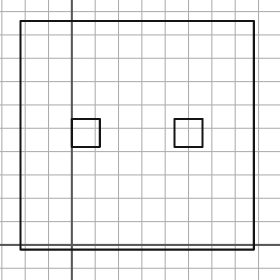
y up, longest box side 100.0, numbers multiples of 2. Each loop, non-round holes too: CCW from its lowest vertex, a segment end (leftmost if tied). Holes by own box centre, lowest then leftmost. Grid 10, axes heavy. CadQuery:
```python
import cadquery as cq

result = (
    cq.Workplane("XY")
    .moveTo(-22.0, -2.0)
    .lineTo(78.0, -2.0)
    .lineTo(78.0, 96.0)
    .lineTo(-22.0, 96.0)
    .close()
    .moveTo(0.0, 42.0)
    .lineTo(12.0, 42.0)
    .lineTo(12.0, 54.0)
    .lineTo(0.0, 54.0)
    .close()
    .moveTo(44.0, 42.0)
    .lineTo(56.0, 42.0)
    .lineTo(56.0, 54.0)
    .lineTo(44.0, 54.0)
    .close()
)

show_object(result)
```